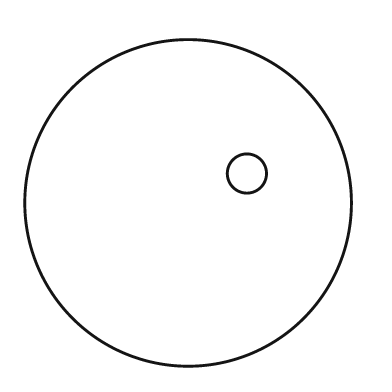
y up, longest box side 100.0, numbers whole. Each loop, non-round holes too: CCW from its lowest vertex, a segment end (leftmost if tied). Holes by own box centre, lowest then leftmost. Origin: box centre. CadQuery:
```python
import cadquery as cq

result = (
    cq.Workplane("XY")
    .moveTo(0.0, 0.0)
    .circle(50.0)
    .moveTo(18.0, 9.0)
    .circle(6.0)
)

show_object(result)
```